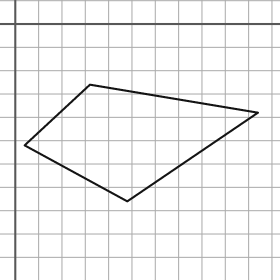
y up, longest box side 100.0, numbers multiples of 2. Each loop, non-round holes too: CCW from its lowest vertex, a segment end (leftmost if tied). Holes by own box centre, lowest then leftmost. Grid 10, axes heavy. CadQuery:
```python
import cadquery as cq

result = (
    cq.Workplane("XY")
    .moveTo(48.0, -76.0)
    .lineTo(104.0, -38.0)
    .lineTo(32.0, -26.0)
    .lineTo(4.0, -52.0)
    .close()
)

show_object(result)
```